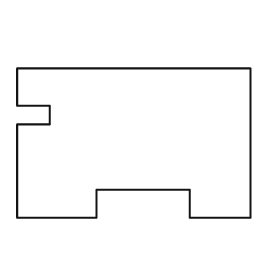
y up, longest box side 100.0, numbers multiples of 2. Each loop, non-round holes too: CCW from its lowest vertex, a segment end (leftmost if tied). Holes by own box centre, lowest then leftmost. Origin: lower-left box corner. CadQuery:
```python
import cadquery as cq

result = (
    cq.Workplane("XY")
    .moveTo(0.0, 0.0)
    .lineTo(34.0, 0.0)
    .lineTo(34.0, 12.0)
    .lineTo(74.0, 12.0)
    .lineTo(74.0, 0.0)
    .lineTo(100.0, 0.0)
    .lineTo(100.0, 64.0)
    .lineTo(0.0, 64.0)
    .lineTo(0.0, 48.0)
    .lineTo(14.0, 48.0)
    .lineTo(14.0, 40.0)
    .lineTo(0.0, 40.0)
    .close()
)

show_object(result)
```